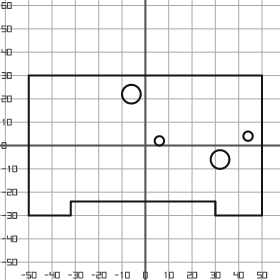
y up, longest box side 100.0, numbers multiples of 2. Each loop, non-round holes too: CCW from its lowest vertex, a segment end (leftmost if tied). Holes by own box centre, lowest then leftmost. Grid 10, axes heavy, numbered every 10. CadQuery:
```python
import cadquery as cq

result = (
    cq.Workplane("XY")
    .moveTo(-50.0, -30.0)
    .lineTo(-32.0, -30.0)
    .lineTo(-32.0, -24.0)
    .lineTo(30.0, -24.0)
    .lineTo(30.0, -30.0)
    .lineTo(50.0, -30.0)
    .lineTo(50.0, 30.0)
    .lineTo(-50.0, 30.0)
    .close()
    .moveTo(32.0, -6.0)
    .circle(4.0)
    .moveTo(6.0, 2.0)
    .circle(2.0)
    .moveTo(44.0, 4.0)
    .circle(2.0)
    .moveTo(-6.0, 22.0)
    .circle(4.0)
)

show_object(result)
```